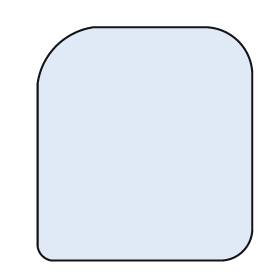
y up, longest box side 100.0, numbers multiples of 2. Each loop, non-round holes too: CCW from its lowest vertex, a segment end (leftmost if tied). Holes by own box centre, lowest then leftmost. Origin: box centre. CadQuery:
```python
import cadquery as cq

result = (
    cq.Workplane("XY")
    .moveTo(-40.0, -50.0)
    .lineTo(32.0, -50.0)
    .threePointArc((42.0, -46.0), (46.0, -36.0))
    .lineTo(46.0, 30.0)
    .threePointArc((40.0, 44.0), (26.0, 50.0))
    .lineTo(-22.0, 50.0)
    .threePointArc((-38.0, 42.0), (-46.0, 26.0))
    .lineTo(-46.0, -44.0)
    .threePointArc((-44.0, -48.0), (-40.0, -50.0))
    .close()
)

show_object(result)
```